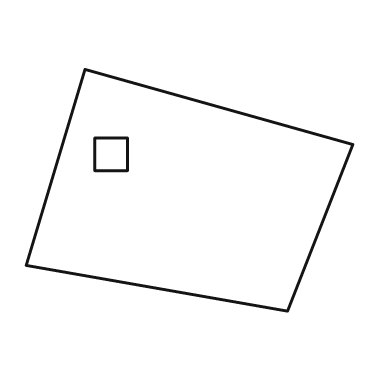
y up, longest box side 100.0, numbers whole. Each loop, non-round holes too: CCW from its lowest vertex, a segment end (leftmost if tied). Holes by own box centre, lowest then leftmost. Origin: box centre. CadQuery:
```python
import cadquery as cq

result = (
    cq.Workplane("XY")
    .moveTo(30.0, -37.0)
    .lineTo(50.0, 14.0)
    .lineTo(-32.0, 37.0)
    .lineTo(-50.0, -23.0)
    .close()
    .moveTo(-29.0, 6.0)
    .lineTo(-19.0, 6.0)
    .lineTo(-19.0, 16.0)
    .lineTo(-29.0, 16.0)
    .close()
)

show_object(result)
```